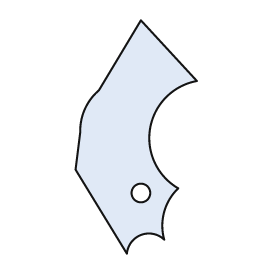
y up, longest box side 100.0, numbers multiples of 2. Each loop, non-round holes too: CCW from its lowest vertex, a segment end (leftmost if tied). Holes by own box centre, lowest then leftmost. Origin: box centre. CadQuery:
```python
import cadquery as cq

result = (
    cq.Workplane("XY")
    .moveTo(-4.0, -50.0)
    .threePointArc((2.0, -42.0), (12.0, -44.0))
    .threePointArc((12.0, -32.0), (18.0, -22.0))
    .threePointArc((6.0, 4.0), (26.0, 24.0))
    .lineTo(2.0, 50.0)
    .lineTo(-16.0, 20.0)
    .threePointArc((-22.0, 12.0), (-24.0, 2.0))
    .lineTo(-26.0, -14.0)
    .close()
    .moveTo(2.0, -24.0)
    .circle(4.0)
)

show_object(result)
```